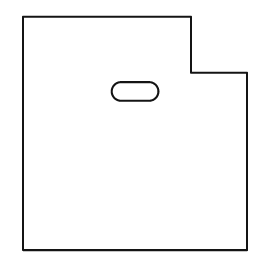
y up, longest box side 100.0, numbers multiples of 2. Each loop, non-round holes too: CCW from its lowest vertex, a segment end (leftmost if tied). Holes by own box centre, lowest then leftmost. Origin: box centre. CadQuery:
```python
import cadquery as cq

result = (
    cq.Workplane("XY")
    .moveTo(-48.0, -50.0)
    .lineTo(48.0, -50.0)
    .lineTo(48.0, 26.0)
    .lineTo(24.0, 26.0)
    .lineTo(24.0, 50.0)
    .lineTo(-48.0, 50.0)
    .close()
    .moveTo(-6.0, 14.0)
    .lineTo(6.0, 14.0)
    .threePointArc((10.0, 18.0), (6.0, 22.0))
    .lineTo(-6.0, 22.0)
    .threePointArc((-10.0, 18.0), (-6.0, 14.0))
    .close()
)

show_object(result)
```